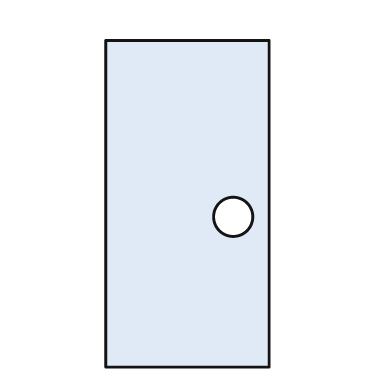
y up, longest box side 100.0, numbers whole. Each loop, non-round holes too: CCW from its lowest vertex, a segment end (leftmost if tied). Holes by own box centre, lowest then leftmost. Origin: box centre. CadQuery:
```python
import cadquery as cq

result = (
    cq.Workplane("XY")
    .moveTo(-25.0, -50.0)
    .lineTo(25.0, -50.0)
    .lineTo(25.0, 50.0)
    .lineTo(-25.0, 50.0)
    .close()
    .moveTo(14.0, -4.0)
    .circle(6.0)
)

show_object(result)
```